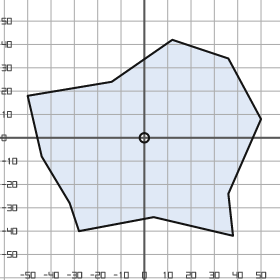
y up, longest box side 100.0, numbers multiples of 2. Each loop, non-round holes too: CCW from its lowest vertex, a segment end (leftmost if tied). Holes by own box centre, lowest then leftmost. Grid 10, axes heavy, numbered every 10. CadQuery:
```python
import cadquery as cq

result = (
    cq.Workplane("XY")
    .moveTo(38.0, -42.0)
    .lineTo(36.0, -24.0)
    .lineTo(50.0, 8.0)
    .lineTo(36.0, 34.0)
    .lineTo(12.0, 42.0)
    .lineTo(-14.0, 24.0)
    .lineTo(-50.0, 18.0)
    .lineTo(-44.0, -8.0)
    .lineTo(-32.0, -28.0)
    .lineTo(-28.0, -40.0)
    .lineTo(4.0, -34.0)
    .close()
    .moveTo(0.0, 0.0)
    .circle(2.0)
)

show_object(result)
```